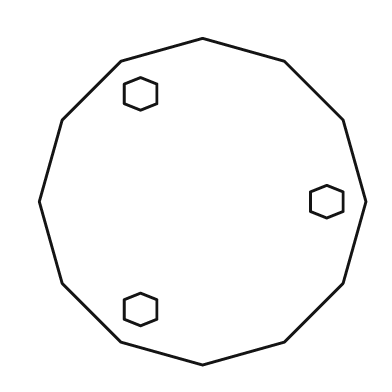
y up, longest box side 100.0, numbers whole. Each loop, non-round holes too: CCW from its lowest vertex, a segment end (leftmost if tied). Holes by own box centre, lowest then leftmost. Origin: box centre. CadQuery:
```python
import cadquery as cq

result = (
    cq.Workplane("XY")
    .moveTo(0.0, -50.0)
    .lineTo(25.0, -43.0)
    .lineTo(43.0, -25.0)
    .lineTo(50.0, 0.0)
    .lineTo(43.0, 25.0)
    .lineTo(25.0, 43.0)
    .lineTo(0.0, 50.0)
    .lineTo(-25.0, 43.0)
    .lineTo(-43.0, 25.0)
    .lineTo(-50.0, 0.0)
    .lineTo(-43.0, -25.0)
    .lineTo(-25.0, -43.0)
    .close()
    .moveTo(-19.0, -38.0)
    .lineTo(-14.0, -36.0)
    .lineTo(-14.0, -30.0)
    .lineTo(-19.0, -28.0)
    .lineTo(-24.0, -30.0)
    .lineTo(-24.0, -36.0)
    .close()
    .moveTo(38.0, -5.0)
    .lineTo(43.0, -3.0)
    .lineTo(43.0, 3.0)
    .lineTo(38.0, 5.0)
    .lineTo(33.0, 3.0)
    .lineTo(33.0, -3.0)
    .close()
    .moveTo(-19.0, 28.0)
    .lineTo(-14.0, 30.0)
    .lineTo(-14.0, 36.0)
    .lineTo(-19.0, 38.0)
    .lineTo(-24.0, 36.0)
    .lineTo(-24.0, 30.0)
    .close()
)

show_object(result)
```